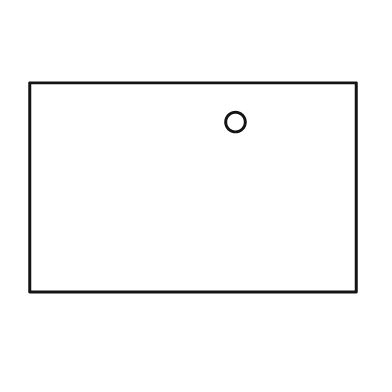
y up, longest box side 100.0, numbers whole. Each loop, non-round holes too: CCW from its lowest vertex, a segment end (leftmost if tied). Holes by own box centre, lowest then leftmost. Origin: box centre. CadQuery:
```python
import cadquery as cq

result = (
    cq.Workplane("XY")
    .moveTo(-50.0, -32.0)
    .lineTo(50.0, -32.0)
    .lineTo(50.0, 32.0)
    .lineTo(-50.0, 32.0)
    .close()
    .moveTo(13.0, 20.0)
    .circle(3.0)
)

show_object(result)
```